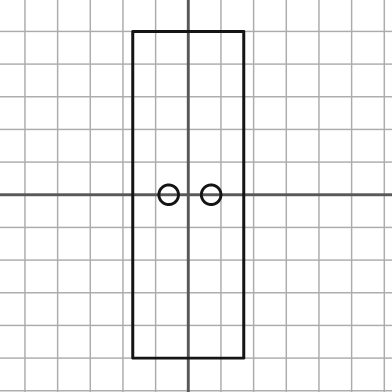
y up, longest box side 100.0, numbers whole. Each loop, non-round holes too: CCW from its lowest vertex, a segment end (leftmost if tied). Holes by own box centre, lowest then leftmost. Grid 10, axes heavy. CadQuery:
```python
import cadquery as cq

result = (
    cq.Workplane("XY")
    .moveTo(-17.0, -50.0)
    .lineTo(17.0, -50.0)
    .lineTo(17.0, 50.0)
    .lineTo(-17.0, 50.0)
    .close()
    .moveTo(-6.0, 0.0)
    .circle(3.0)
    .moveTo(7.0, 0.0)
    .circle(3.0)
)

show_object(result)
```